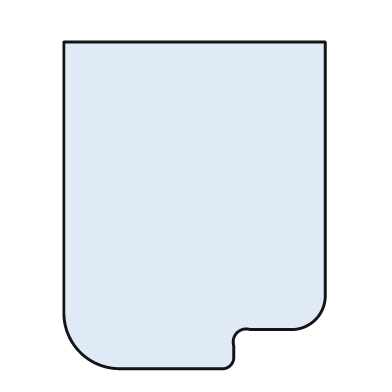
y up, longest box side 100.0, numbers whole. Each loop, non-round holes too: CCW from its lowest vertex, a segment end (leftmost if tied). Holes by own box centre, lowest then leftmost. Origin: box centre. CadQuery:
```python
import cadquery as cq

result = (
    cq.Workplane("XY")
    .moveTo(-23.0, -50.0)
    .lineTo(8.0, -50.0)
    .threePointArc((11.0, -49.0), (12.0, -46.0))
    .lineTo(12.0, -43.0)
    .threePointArc((13.0, -39.0), (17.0, -38.0))
    .lineTo(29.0, -38.0)
    .threePointArc((37.0, -35.0), (40.0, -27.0))
    .lineTo(40.0, 50.0)
    .lineTo(-40.0, 50.0)
    .lineTo(-40.0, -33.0)
    .threePointArc((-35.0, -45.0), (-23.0, -50.0))
    .close()
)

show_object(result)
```